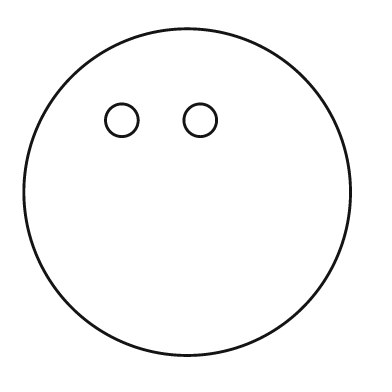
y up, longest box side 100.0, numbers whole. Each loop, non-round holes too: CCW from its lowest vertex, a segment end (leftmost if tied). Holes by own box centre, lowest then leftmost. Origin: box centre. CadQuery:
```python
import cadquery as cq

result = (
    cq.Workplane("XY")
    .moveTo(0.0, 0.0)
    .circle(50.0)
    .moveTo(-20.0, 22.0)
    .circle(5.0)
    .moveTo(4.0, 22.0)
    .circle(5.0)
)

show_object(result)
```